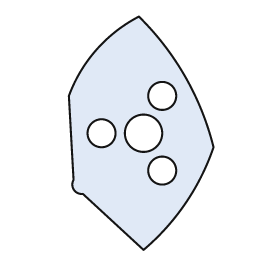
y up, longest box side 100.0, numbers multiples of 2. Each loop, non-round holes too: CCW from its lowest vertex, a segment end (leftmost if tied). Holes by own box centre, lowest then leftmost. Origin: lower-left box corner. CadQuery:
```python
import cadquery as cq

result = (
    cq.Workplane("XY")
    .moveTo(32.0, 0.0)
    .threePointArc((50.0, 20.0), (62.0, 44.0))
    .threePointArc((50.0, 74.0), (30.0, 100.0))
    .threePointArc((12.0, 86.0), (0.0, 66.0))
    .lineTo(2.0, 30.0)
    .threePointArc((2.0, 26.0), (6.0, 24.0))
    .close()
    .moveTo(40.0, 34.0)
    .circle(6.0)
    .moveTo(14.0, 50.0)
    .circle(6.0)
    .moveTo(32.0, 50.0)
    .circle(8.0)
    .moveTo(40.0, 66.0)
    .circle(6.0)
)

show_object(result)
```